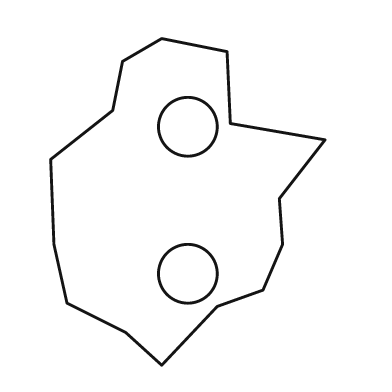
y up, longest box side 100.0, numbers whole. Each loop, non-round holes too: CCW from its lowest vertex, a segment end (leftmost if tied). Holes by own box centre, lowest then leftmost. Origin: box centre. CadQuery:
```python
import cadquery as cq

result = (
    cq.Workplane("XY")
    .moveTo(-8.0, -50.0)
    .lineTo(9.0, -32.0)
    .lineTo(23.0, -27.0)
    .lineTo(29.0, -13.0)
    .lineTo(28.0, 1.0)
    .lineTo(42.0, 19.0)
    .lineTo(13.0, 24.0)
    .lineTo(12.0, 46.0)
    .lineTo(-8.0, 50.0)
    .lineTo(-20.0, 43.0)
    .lineTo(-23.0, 28.0)
    .lineTo(-42.0, 13.0)
    .lineTo(-41.0, -13.0)
    .lineTo(-37.0, -31.0)
    .lineTo(-19.0, -40.0)
    .close()
    .moveTo(0.0, -22.0)
    .circle(9.0)
    .moveTo(0.0, 23.0)
    .circle(9.0)
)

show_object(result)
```